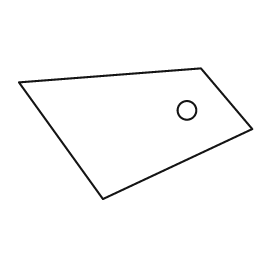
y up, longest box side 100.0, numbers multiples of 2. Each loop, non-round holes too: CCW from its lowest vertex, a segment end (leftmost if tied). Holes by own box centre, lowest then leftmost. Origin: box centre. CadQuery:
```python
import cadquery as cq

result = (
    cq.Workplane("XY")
    .moveTo(-14.0, -28.0)
    .lineTo(50.0, 2.0)
    .lineTo(28.0, 28.0)
    .lineTo(-50.0, 22.0)
    .close()
    .moveTo(22.0, 10.0)
    .circle(4.0)
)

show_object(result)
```